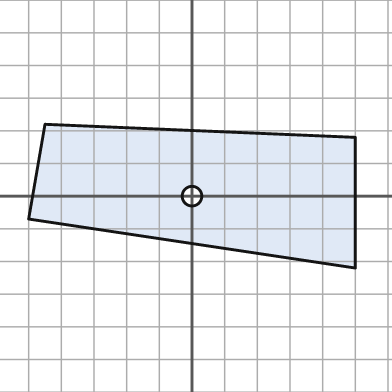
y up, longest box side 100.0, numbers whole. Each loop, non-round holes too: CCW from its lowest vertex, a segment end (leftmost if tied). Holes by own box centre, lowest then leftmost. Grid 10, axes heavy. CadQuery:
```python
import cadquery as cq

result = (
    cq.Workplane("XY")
    .moveTo(50.0, -22.0)
    .lineTo(50.0, 18.0)
    .lineTo(-45.0, 22.0)
    .lineTo(-50.0, -7.0)
    .close()
    .moveTo(0.0, 0.0)
    .circle(3.0)
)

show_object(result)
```